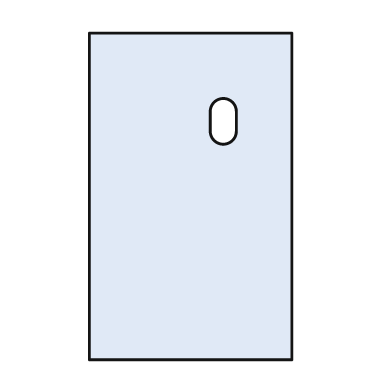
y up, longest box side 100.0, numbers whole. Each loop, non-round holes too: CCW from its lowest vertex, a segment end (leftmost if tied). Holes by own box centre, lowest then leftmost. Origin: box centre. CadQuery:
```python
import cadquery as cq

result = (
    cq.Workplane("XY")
    .moveTo(-31.0, -50.0)
    .lineTo(31.0, -50.0)
    .lineTo(31.0, 50.0)
    .lineTo(-31.0, 50.0)
    .close()
    .moveTo(6.0, 20.0)
    .threePointArc((10.0, 16.0), (14.0, 20.0))
    .lineTo(14.0, 26.0)
    .threePointArc((10.0, 30.0), (6.0, 26.0))
    .close()
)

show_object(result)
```